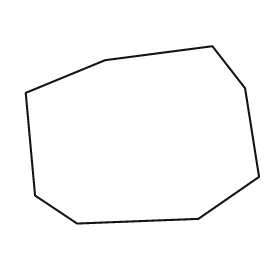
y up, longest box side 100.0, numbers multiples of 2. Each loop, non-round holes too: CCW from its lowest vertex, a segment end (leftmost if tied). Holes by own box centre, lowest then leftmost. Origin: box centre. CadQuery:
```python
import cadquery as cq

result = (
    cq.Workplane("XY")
    .moveTo(-28.0, -38.0)
    .lineTo(24.0, -36.0)
    .lineTo(50.0, -18.0)
    .lineTo(44.0, 20.0)
    .lineTo(30.0, 38.0)
    .lineTo(-16.0, 32.0)
    .lineTo(-50.0, 18.0)
    .lineTo(-46.0, -26.0)
    .close()
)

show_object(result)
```